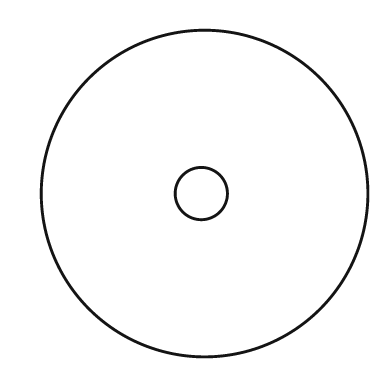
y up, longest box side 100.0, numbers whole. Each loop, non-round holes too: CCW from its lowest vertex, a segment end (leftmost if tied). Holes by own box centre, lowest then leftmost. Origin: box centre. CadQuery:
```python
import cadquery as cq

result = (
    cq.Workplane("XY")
    .moveTo(0.0, 0.0)
    .circle(50.0)
    .moveTo(-1.0, 0.0)
    .circle(8.0)
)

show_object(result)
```